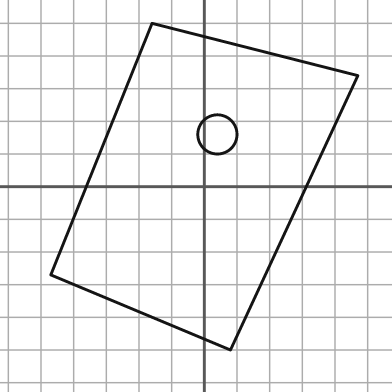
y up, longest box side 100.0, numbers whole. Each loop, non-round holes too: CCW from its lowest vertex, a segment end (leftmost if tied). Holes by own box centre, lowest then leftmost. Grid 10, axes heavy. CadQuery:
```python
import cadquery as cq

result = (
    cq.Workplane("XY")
    .moveTo(8.0, -50.0)
    .lineTo(47.0, 34.0)
    .lineTo(-16.0, 50.0)
    .lineTo(-47.0, -27.0)
    .close()
    .moveTo(4.0, 16.0)
    .circle(6.0)
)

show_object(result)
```